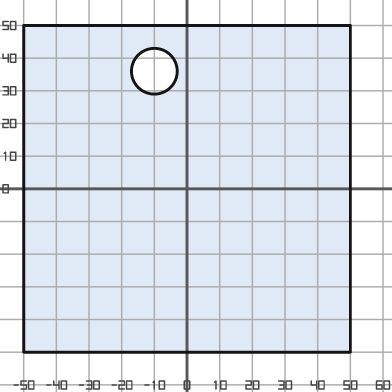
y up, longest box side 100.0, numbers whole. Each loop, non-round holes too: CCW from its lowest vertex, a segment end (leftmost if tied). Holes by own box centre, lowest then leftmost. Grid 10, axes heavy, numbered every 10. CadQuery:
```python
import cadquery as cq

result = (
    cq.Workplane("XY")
    .moveTo(-50.0, -50.0)
    .lineTo(50.0, -50.0)
    .lineTo(50.0, 50.0)
    .lineTo(-50.0, 50.0)
    .close()
    .moveTo(-10.0, 36.0)
    .circle(7.0)
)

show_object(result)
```